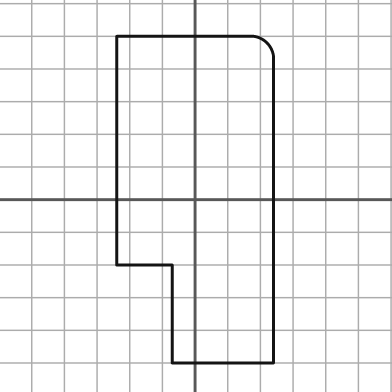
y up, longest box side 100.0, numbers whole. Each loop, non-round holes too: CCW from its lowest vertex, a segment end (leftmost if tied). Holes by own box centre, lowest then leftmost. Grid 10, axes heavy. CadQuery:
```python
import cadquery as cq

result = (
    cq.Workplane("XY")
    .moveTo(-7.0, -50.0)
    .lineTo(24.0, -50.0)
    .lineTo(24.0, 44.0)
    .threePointArc((22.0, 48.0), (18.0, 50.0))
    .lineTo(-24.0, 50.0)
    .lineTo(-24.0, -20.0)
    .lineTo(-7.0, -20.0)
    .close()
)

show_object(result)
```